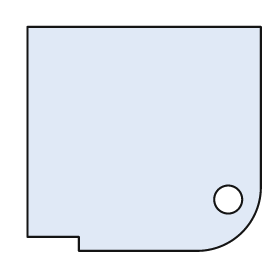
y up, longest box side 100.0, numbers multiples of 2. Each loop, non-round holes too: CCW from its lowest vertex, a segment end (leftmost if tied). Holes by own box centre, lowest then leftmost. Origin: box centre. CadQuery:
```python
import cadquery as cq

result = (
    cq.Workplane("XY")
    .moveTo(-28.0, -48.0)
    .lineTo(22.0, -48.0)
    .threePointArc((42.0, -40.0), (50.0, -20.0))
    .lineTo(50.0, 48.0)
    .lineTo(-50.0, 48.0)
    .lineTo(-50.0, -42.0)
    .lineTo(-28.0, -42.0)
    .close()
    .moveTo(36.0, -26.0)
    .circle(6.0)
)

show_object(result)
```